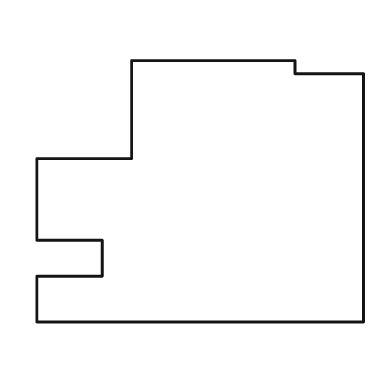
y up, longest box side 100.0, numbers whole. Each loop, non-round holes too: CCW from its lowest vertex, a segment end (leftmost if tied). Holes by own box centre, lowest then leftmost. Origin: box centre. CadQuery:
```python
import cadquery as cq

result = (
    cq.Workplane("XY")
    .moveTo(-50.0, -40.0)
    .lineTo(50.0, -40.0)
    .lineTo(50.0, 36.0)
    .lineTo(29.0, 36.0)
    .lineTo(29.0, 40.0)
    .lineTo(-21.0, 40.0)
    .lineTo(-21.0, 10.0)
    .lineTo(-50.0, 10.0)
    .lineTo(-50.0, -15.0)
    .lineTo(-30.0, -15.0)
    .lineTo(-30.0, -26.0)
    .lineTo(-50.0, -26.0)
    .close()
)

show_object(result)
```